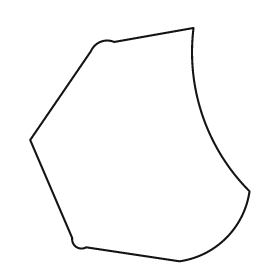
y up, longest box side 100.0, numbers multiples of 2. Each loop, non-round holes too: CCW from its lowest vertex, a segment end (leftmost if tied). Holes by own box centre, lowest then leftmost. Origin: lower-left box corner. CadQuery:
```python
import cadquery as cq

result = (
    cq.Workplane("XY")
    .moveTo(64.0, 0.0)
    .threePointArc((84.0, 10.0), (94.0, 30.0))
    .threePointArc((74.0, 62.0), (70.0, 100.0))
    .lineTo(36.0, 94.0)
    .threePointArc((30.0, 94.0), (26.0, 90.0))
    .lineTo(0.0, 52.0)
    .lineTo(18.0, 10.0)
    .threePointArc((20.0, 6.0), (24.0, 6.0))
    .close()
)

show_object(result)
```